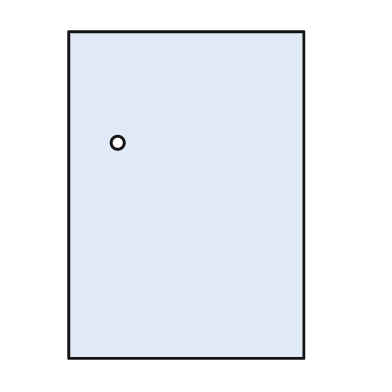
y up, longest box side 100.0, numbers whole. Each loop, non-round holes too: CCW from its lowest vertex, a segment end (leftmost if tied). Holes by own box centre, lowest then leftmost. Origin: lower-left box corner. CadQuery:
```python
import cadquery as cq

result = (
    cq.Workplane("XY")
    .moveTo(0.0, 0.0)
    .lineTo(72.0, 0.0)
    .lineTo(72.0, 100.0)
    .lineTo(0.0, 100.0)
    .close()
    .moveTo(15.0, 66.0)
    .circle(2.0)
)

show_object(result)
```